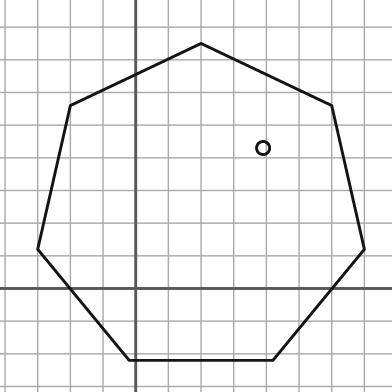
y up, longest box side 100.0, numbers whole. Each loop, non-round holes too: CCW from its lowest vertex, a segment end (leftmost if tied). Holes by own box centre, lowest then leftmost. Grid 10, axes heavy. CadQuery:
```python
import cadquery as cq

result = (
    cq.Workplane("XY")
    .moveTo(-2.0, -22.0)
    .lineTo(42.0, -22.0)
    .lineTo(70.0, 12.0)
    .lineTo(60.0, 56.0)
    .lineTo(20.0, 75.0)
    .lineTo(-20.0, 56.0)
    .lineTo(-30.0, 12.0)
    .close()
    .moveTo(39.0, 43.0)
    .circle(2.0)
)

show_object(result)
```